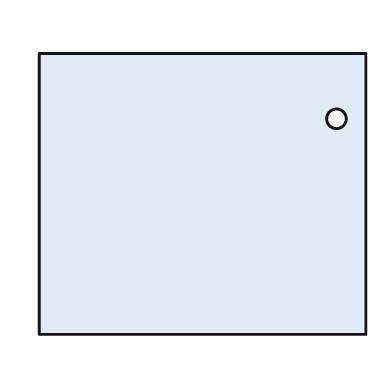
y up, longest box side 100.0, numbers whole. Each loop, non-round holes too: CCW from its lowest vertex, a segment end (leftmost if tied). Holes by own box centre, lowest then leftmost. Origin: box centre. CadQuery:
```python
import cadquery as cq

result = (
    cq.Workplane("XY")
    .moveTo(-50.0, -43.0)
    .lineTo(50.0, -43.0)
    .lineTo(50.0, 43.0)
    .lineTo(-50.0, 43.0)
    .close()
    .moveTo(41.0, 23.0)
    .circle(3.0)
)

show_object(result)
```